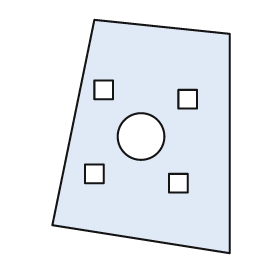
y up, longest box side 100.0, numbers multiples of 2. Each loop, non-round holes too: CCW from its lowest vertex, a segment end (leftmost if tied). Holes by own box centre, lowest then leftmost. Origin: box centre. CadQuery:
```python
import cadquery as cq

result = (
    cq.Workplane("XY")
    .moveTo(38.0, -50.0)
    .lineTo(38.0, 44.0)
    .lineTo(-20.0, 50.0)
    .lineTo(-38.0, -38.0)
    .close()
    .moveTo(12.0, -24.0)
    .lineTo(20.0, -24.0)
    .lineTo(20.0, -16.0)
    .lineTo(12.0, -16.0)
    .close()
    .moveTo(-24.0, -20.0)
    .lineTo(-16.0, -20.0)
    .lineTo(-16.0, -12.0)
    .lineTo(-24.0, -12.0)
    .close()
    .moveTo(0.0, 0.0)
    .circle(10.0)
    .moveTo(16.0, 12.0)
    .lineTo(24.0, 12.0)
    .lineTo(24.0, 20.0)
    .lineTo(16.0, 20.0)
    .close()
    .moveTo(-20.0, 16.0)
    .lineTo(-12.0, 16.0)
    .lineTo(-12.0, 24.0)
    .lineTo(-20.0, 24.0)
    .close()
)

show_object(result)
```